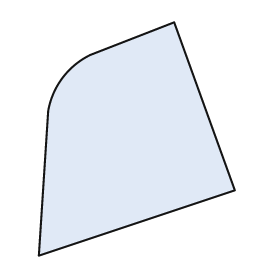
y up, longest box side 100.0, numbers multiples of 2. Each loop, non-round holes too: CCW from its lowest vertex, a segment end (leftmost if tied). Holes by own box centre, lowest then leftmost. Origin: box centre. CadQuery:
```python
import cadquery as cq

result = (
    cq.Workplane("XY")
    .moveTo(-42.0, -50.0)
    .lineTo(42.0, -22.0)
    .lineTo(16.0, 50.0)
    .lineTo(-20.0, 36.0)
    .threePointArc((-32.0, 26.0), (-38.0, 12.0))
    .close()
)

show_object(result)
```